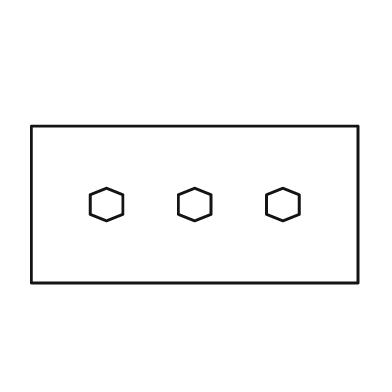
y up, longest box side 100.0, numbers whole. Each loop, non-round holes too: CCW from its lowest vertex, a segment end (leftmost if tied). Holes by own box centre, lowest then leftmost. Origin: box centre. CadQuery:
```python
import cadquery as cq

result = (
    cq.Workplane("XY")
    .moveTo(-50.0, -24.0)
    .lineTo(50.0, -24.0)
    .lineTo(50.0, 24.0)
    .lineTo(-50.0, 24.0)
    .close()
    .moveTo(-27.0, -5.0)
    .lineTo(-22.0, -3.0)
    .lineTo(-22.0, 3.0)
    .lineTo(-27.0, 5.0)
    .lineTo(-32.0, 3.0)
    .lineTo(-32.0, -3.0)
    .close()
    .moveTo(0.0, -5.0)
    .lineTo(5.0, -3.0)
    .lineTo(5.0, 3.0)
    .lineTo(0.0, 5.0)
    .lineTo(-5.0, 3.0)
    .lineTo(-5.0, -3.0)
    .close()
    .moveTo(27.0, -5.0)
    .lineTo(32.0, -3.0)
    .lineTo(32.0, 3.0)
    .lineTo(27.0, 5.0)
    .lineTo(22.0, 3.0)
    .lineTo(22.0, -3.0)
    .close()
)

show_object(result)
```